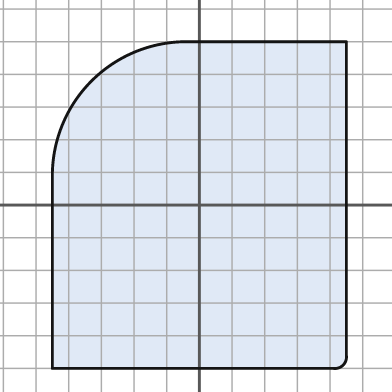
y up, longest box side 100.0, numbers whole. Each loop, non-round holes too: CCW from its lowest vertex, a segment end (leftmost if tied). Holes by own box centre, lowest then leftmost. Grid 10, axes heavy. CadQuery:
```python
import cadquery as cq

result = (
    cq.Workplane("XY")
    .moveTo(-45.0, -50.0)
    .lineTo(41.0, -50.0)
    .threePointArc((44.0, -49.0), (45.0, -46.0))
    .lineTo(45.0, 50.0)
    .lineTo(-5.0, 50.0)
    .threePointArc((-33.0, 38.0), (-45.0, 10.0))
    .close()
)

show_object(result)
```